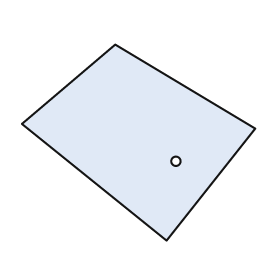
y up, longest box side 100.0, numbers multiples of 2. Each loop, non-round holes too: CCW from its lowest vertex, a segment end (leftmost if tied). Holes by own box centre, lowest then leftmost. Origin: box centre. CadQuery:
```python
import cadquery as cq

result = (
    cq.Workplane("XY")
    .moveTo(12.0, -42.0)
    .lineTo(50.0, 6.0)
    .lineTo(-10.0, 42.0)
    .lineTo(-50.0, 8.0)
    .close()
    .moveTo(16.0, -8.0)
    .circle(2.0)
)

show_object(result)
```